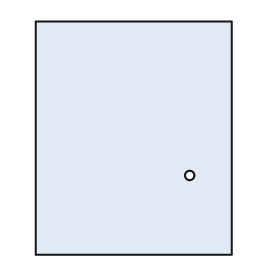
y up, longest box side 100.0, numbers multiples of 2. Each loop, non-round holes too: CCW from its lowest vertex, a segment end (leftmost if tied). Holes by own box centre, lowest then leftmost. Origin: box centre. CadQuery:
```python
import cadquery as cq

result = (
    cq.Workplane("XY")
    .moveTo(-42.0, -50.0)
    .lineTo(42.0, -50.0)
    .lineTo(42.0, 50.0)
    .lineTo(-42.0, 50.0)
    .close()
    .moveTo(24.0, -16.0)
    .circle(2.0)
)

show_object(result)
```